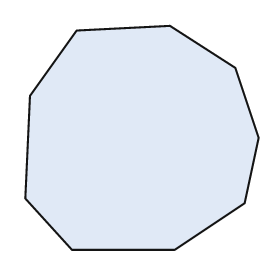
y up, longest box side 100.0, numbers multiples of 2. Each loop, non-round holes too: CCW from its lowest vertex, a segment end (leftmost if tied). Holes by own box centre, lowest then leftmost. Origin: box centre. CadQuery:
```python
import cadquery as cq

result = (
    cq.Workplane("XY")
    .moveTo(-30.0, -48.0)
    .lineTo(14.0, -48.0)
    .lineTo(44.0, -28.0)
    .lineTo(50.0, 0.0)
    .lineTo(40.0, 30.0)
    .lineTo(12.0, 48.0)
    .lineTo(-28.0, 46.0)
    .lineTo(-48.0, 18.0)
    .lineTo(-50.0, -26.0)
    .close()
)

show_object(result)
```